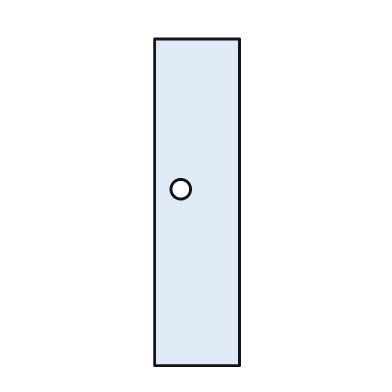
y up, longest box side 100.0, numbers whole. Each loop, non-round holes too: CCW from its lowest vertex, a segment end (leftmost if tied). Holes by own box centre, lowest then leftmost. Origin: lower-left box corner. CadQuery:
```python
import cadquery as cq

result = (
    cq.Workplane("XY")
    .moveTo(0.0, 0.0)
    .lineTo(26.0, 0.0)
    .lineTo(26.0, 100.0)
    .lineTo(0.0, 100.0)
    .close()
    .moveTo(8.0, 54.0)
    .circle(3.0)
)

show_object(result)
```